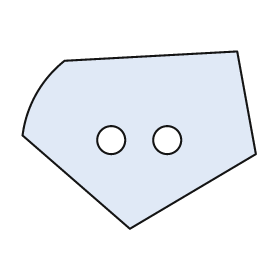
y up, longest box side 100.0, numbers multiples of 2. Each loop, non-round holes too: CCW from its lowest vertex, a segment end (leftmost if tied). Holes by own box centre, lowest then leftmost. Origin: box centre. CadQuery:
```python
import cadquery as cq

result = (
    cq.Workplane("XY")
    .moveTo(-4.0, -38.0)
    .lineTo(50.0, -6.0)
    .lineTo(42.0, 38.0)
    .lineTo(-32.0, 34.0)
    .threePointArc((-44.0, 20.0), (-50.0, 2.0))
    .close()
    .moveTo(-12.0, 0.0)
    .circle(6.0)
    .moveTo(12.0, 0.0)
    .circle(6.0)
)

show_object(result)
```